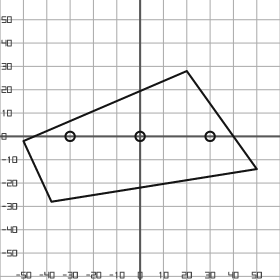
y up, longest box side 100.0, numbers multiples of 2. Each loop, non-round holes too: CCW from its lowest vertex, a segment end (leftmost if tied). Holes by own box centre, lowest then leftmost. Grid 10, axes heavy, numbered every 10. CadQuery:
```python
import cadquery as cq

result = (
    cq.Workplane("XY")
    .moveTo(-38.0, -28.0)
    .lineTo(50.0, -14.0)
    .lineTo(20.0, 28.0)
    .lineTo(-50.0, -2.0)
    .close()
    .moveTo(-30.0, 0.0)
    .circle(2.0)
    .moveTo(0.0, 0.0)
    .circle(2.0)
    .moveTo(30.0, 0.0)
    .circle(2.0)
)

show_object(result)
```